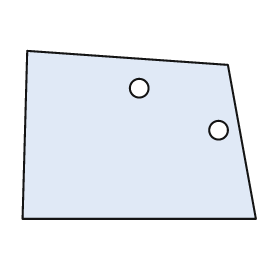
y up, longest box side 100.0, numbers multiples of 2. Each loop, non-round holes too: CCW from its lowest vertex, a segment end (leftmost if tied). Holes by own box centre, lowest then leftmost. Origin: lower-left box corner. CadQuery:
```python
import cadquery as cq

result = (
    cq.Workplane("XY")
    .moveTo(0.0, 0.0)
    .lineTo(100.0, 0.0)
    .lineTo(88.0, 66.0)
    .lineTo(2.0, 72.0)
    .close()
    .moveTo(84.0, 38.0)
    .circle(4.0)
    .moveTo(50.0, 56.0)
    .circle(4.0)
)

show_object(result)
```